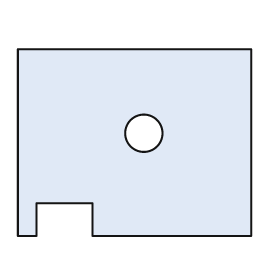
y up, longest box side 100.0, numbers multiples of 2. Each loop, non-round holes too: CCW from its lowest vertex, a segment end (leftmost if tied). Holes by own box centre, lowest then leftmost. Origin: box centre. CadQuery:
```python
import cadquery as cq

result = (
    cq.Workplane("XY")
    .moveTo(-50.0, -40.0)
    .lineTo(-42.0, -40.0)
    .lineTo(-42.0, -26.0)
    .lineTo(-18.0, -26.0)
    .lineTo(-18.0, -40.0)
    .lineTo(50.0, -40.0)
    .lineTo(50.0, 40.0)
    .lineTo(-50.0, 40.0)
    .close()
    .moveTo(4.0, 4.0)
    .circle(8.0)
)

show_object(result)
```